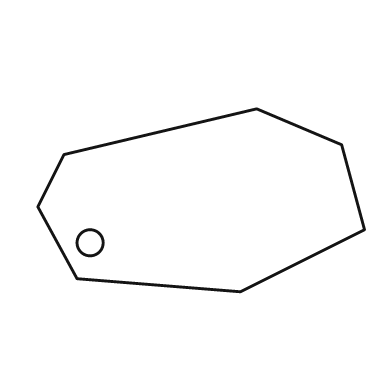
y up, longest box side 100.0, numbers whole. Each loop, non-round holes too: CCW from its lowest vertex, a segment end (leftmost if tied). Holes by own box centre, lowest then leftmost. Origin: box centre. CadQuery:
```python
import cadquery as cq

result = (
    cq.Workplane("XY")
    .moveTo(12.0, -28.0)
    .lineTo(50.0, -9.0)
    .lineTo(43.0, 17.0)
    .lineTo(17.0, 28.0)
    .lineTo(-42.0, 14.0)
    .lineTo(-50.0, -2.0)
    .lineTo(-38.0, -24.0)
    .close()
    .moveTo(-34.0, -13.0)
    .circle(4.0)
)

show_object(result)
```